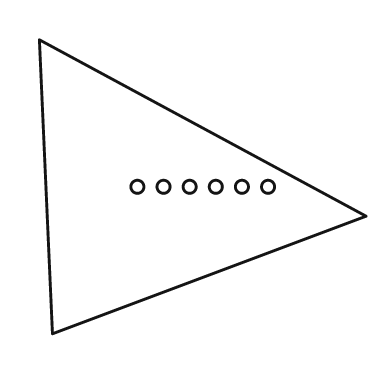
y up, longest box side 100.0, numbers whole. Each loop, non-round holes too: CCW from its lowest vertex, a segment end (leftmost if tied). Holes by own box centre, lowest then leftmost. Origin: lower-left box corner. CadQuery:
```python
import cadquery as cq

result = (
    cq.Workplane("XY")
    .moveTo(4.0, 0.0)
    .lineTo(100.0, 36.0)
    .lineTo(0.0, 90.0)
    .close()
    .moveTo(30.0, 45.0)
    .circle(2.0)
    .moveTo(38.0, 45.0)
    .circle(2.0)
    .moveTo(46.0, 45.0)
    .circle(2.0)
    .moveTo(54.0, 45.0)
    .circle(2.0)
    .moveTo(62.0, 45.0)
    .circle(2.0)
    .moveTo(70.0, 45.0)
    .circle(2.0)
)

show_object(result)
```